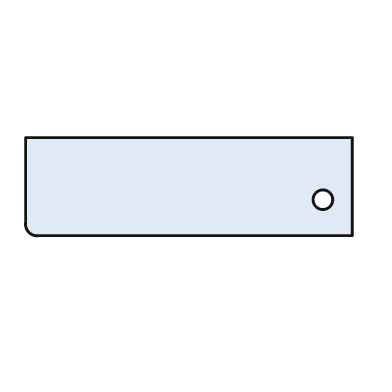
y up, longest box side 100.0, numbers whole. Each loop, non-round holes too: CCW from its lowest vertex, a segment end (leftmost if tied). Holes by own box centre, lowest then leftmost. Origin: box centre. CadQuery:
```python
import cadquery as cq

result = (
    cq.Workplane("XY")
    .moveTo(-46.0, -15.0)
    .lineTo(50.0, -15.0)
    .lineTo(50.0, 15.0)
    .lineTo(-50.0, 15.0)
    .lineTo(-50.0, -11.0)
    .threePointArc((-49.0, -14.0), (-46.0, -15.0))
    .close()
    .moveTo(41.0, -4.0)
    .circle(3.0)
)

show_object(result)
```